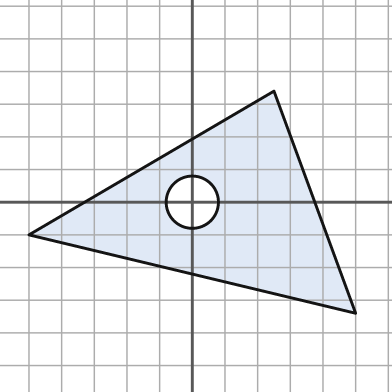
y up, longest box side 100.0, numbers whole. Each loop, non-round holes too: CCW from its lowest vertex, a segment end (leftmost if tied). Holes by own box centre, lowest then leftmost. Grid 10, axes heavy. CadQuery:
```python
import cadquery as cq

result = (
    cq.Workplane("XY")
    .moveTo(50.0, -34.0)
    .lineTo(25.0, 34.0)
    .lineTo(-50.0, -10.0)
    .close()
    .moveTo(0.0, 0.0)
    .circle(8.0)
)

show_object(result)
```